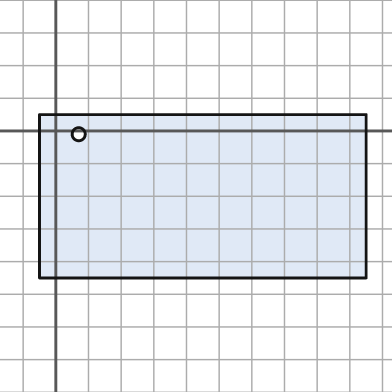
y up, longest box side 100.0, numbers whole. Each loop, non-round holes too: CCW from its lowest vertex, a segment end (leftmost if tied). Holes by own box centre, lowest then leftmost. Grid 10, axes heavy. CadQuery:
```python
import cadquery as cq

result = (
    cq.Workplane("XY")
    .moveTo(-5.0, -45.0)
    .lineTo(95.0, -45.0)
    .lineTo(95.0, 5.0)
    .lineTo(-5.0, 5.0)
    .close()
    .moveTo(7.0, -1.0)
    .circle(2.0)
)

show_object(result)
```